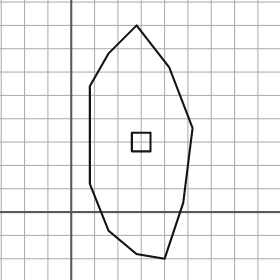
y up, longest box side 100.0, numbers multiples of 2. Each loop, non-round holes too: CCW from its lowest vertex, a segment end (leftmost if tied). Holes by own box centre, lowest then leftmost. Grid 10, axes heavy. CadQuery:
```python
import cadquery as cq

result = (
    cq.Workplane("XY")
    .moveTo(40.0, -20.0)
    .lineTo(48.0, 4.0)
    .lineTo(52.0, 36.0)
    .lineTo(42.0, 62.0)
    .lineTo(28.0, 80.0)
    .lineTo(16.0, 68.0)
    .lineTo(8.0, 54.0)
    .lineTo(8.0, 12.0)
    .lineTo(16.0, -8.0)
    .lineTo(28.0, -18.0)
    .close()
    .moveTo(26.0, 26.0)
    .lineTo(34.0, 26.0)
    .lineTo(34.0, 34.0)
    .lineTo(26.0, 34.0)
    .close()
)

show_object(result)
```